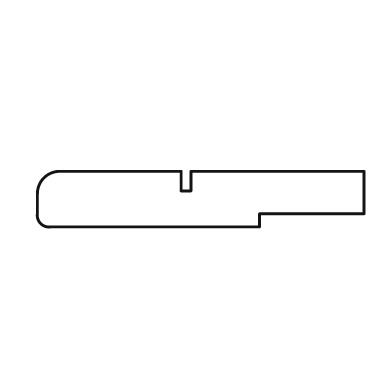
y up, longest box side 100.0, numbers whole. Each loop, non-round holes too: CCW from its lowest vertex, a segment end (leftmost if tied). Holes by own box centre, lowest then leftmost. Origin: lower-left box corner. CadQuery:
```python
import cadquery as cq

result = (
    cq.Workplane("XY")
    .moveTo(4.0, 0.0)
    .lineTo(68.0, 0.0)
    .lineTo(68.0, 4.0)
    .lineTo(100.0, 4.0)
    .lineTo(100.0, 17.0)
    .lineTo(47.0, 17.0)
    .lineTo(47.0, 11.0)
    .lineTo(44.0, 11.0)
    .lineTo(44.0, 17.0)
    .lineTo(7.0, 17.0)
    .threePointArc((2.0, 15.0), (0.0, 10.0))
    .lineTo(0.0, 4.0)
    .threePointArc((1.0, 1.0), (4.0, 0.0))
    .close()
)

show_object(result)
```